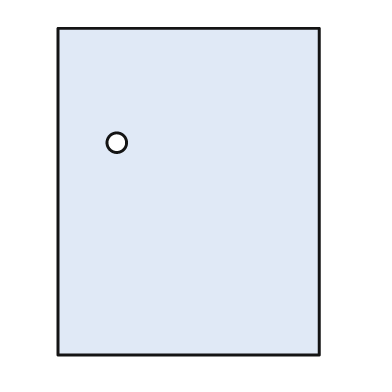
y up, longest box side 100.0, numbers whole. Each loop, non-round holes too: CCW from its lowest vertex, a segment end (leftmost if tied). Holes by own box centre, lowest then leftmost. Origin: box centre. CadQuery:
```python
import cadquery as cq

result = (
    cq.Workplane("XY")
    .moveTo(-40.0, -50.0)
    .lineTo(40.0, -50.0)
    .lineTo(40.0, 50.0)
    .lineTo(-40.0, 50.0)
    .close()
    .moveTo(-22.0, 15.0)
    .circle(3.0)
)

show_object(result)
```